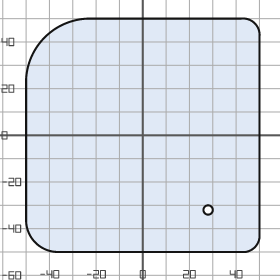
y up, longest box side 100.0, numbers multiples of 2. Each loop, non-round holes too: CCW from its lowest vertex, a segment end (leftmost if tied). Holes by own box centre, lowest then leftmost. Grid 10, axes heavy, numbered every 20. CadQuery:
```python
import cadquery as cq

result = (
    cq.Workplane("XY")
    .moveTo(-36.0, -50.0)
    .lineTo(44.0, -50.0)
    .threePointArc((48.0, -48.0), (50.0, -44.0))
    .lineTo(50.0, 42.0)
    .threePointArc((48.0, 48.0), (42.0, 50.0))
    .lineTo(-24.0, 50.0)
    .threePointArc((-42.0, 42.0), (-50.0, 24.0))
    .lineTo(-50.0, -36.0)
    .threePointArc((-46.0, -46.0), (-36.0, -50.0))
    .close()
    .moveTo(28.0, -32.0)
    .circle(2.0)
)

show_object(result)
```